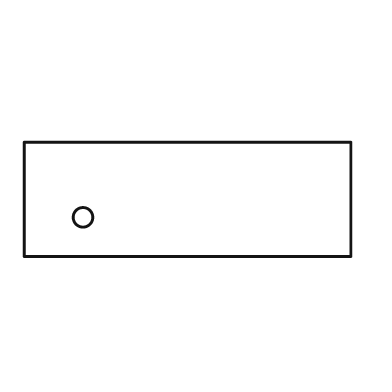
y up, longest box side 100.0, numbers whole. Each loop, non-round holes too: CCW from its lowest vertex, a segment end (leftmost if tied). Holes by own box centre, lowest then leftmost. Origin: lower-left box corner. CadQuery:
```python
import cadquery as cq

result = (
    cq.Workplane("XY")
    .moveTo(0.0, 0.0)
    .lineTo(100.0, 0.0)
    .lineTo(100.0, 35.0)
    .lineTo(0.0, 35.0)
    .close()
    .moveTo(18.0, 12.0)
    .circle(3.0)
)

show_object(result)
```